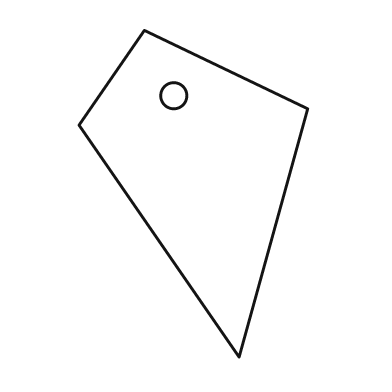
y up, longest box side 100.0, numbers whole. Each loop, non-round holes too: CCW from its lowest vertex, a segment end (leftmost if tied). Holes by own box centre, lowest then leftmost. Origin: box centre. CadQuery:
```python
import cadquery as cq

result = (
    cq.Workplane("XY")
    .moveTo(14.0, -50.0)
    .lineTo(35.0, 26.0)
    .lineTo(-15.0, 50.0)
    .lineTo(-35.0, 21.0)
    .close()
    .moveTo(-6.0, 30.0)
    .circle(4.0)
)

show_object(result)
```